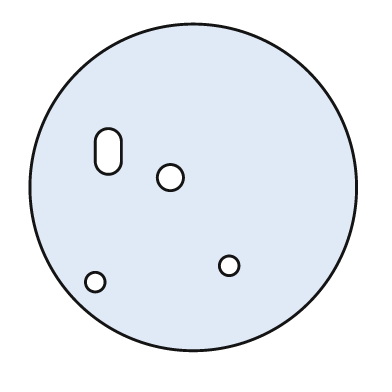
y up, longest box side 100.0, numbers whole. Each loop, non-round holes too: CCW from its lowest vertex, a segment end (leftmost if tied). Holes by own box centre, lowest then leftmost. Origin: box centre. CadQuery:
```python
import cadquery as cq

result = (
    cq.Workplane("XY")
    .moveTo(0.0, 0.0)
    .circle(50.0)
    .moveTo(-30.0, -29.0)
    .circle(3.0)
    .moveTo(11.0, -24.0)
    .circle(3.0)
    .moveTo(-7.0, 3.0)
    .circle(4.0)
    .moveTo(-30.0, 8.0)
    .threePointArc((-26.0, 4.0), (-22.0, 8.0))
    .lineTo(-22.0, 14.0)
    .threePointArc((-26.0, 18.0), (-30.0, 14.0))
    .close()
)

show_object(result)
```